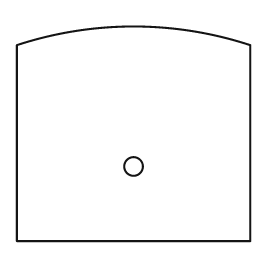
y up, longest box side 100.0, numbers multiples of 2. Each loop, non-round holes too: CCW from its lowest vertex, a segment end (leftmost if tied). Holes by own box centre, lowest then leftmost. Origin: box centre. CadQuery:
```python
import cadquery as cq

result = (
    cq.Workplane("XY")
    .moveTo(-50.0, -46.0)
    .lineTo(50.0, -46.0)
    .lineTo(50.0, 38.0)
    .threePointArc((0.0, 46.0), (-50.0, 38.0))
    .close()
    .moveTo(0.0, -14.0)
    .circle(4.0)
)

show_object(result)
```